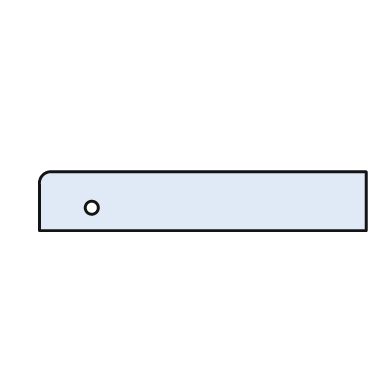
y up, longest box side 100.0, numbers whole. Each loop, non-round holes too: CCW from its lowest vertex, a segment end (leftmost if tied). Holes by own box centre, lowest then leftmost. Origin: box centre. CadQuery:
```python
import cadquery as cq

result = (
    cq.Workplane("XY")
    .moveTo(-50.0, -9.0)
    .lineTo(50.0, -9.0)
    .lineTo(50.0, 9.0)
    .lineTo(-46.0, 9.0)
    .threePointArc((-49.0, 8.0), (-50.0, 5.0))
    .close()
    .moveTo(-34.0, -2.0)
    .circle(2.0)
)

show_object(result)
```